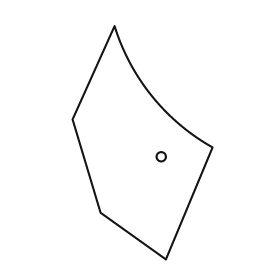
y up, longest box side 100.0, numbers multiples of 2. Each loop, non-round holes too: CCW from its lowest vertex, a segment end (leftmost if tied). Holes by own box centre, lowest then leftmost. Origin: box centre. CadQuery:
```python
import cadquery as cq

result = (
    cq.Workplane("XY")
    .moveTo(10.0, -50.0)
    .lineTo(30.0, -2.0)
    .threePointArc((4.0, 20.0), (-12.0, 50.0))
    .lineTo(-30.0, 10.0)
    .lineTo(-18.0, -30.0)
    .close()
    .moveTo(8.0, -6.0)
    .circle(2.0)
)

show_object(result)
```